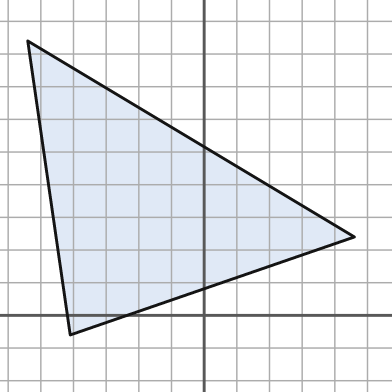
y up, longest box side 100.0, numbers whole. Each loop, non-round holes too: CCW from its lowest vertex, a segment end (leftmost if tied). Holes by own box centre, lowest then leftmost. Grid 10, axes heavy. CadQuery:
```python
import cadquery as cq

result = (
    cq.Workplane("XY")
    .moveTo(-41.0, -6.0)
    .lineTo(46.0, 24.0)
    .lineTo(-54.0, 84.0)
    .close()
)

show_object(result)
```